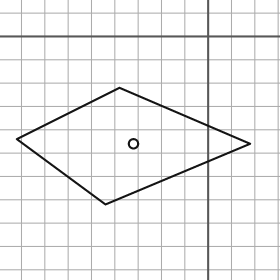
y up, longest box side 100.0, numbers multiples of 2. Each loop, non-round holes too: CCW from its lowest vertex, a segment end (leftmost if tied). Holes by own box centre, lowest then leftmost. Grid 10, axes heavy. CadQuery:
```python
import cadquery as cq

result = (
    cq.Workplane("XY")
    .moveTo(-44.0, -72.0)
    .lineTo(18.0, -46.0)
    .lineTo(-38.0, -22.0)
    .lineTo(-82.0, -44.0)
    .close()
    .moveTo(-32.0, -46.0)
    .circle(2.0)
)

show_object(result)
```